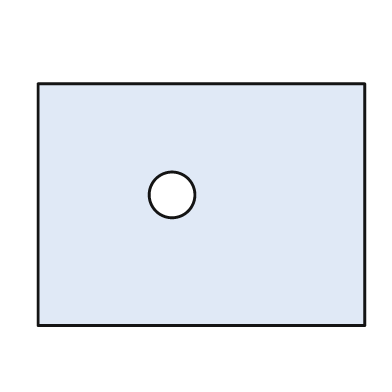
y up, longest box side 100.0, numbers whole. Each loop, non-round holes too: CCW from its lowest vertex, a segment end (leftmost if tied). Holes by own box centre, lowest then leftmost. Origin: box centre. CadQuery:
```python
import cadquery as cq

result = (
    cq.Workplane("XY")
    .moveTo(-50.0, -37.0)
    .lineTo(50.0, -37.0)
    .lineTo(50.0, 37.0)
    .lineTo(-50.0, 37.0)
    .close()
    .moveTo(-9.0, 3.0)
    .circle(7.0)
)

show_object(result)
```